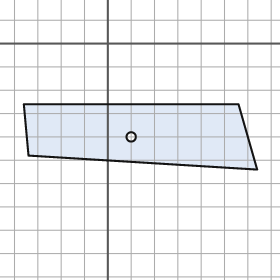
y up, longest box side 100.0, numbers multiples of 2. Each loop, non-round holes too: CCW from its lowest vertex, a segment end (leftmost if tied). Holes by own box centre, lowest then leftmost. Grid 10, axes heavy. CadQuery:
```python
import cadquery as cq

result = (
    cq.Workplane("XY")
    .moveTo(64.0, -54.0)
    .lineTo(56.0, -26.0)
    .lineTo(-36.0, -26.0)
    .lineTo(-34.0, -48.0)
    .close()
    .moveTo(10.0, -40.0)
    .circle(2.0)
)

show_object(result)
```